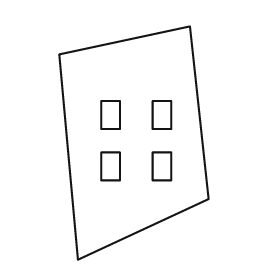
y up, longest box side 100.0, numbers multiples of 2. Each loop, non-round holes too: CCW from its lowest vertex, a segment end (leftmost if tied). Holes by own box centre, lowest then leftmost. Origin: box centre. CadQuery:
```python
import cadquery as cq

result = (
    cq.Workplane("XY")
    .moveTo(-24.0, -50.0)
    .lineTo(32.0, -24.0)
    .lineTo(24.0, 50.0)
    .lineTo(-32.0, 38.0)
    .close()
    .moveTo(-14.0, -16.0)
    .lineTo(-6.0, -16.0)
    .lineTo(-6.0, -4.0)
    .lineTo(-14.0, -4.0)
    .close()
    .moveTo(8.0, -16.0)
    .lineTo(16.0, -16.0)
    .lineTo(16.0, -4.0)
    .lineTo(8.0, -4.0)
    .close()
    .moveTo(-14.0, 6.0)
    .lineTo(-6.0, 6.0)
    .lineTo(-6.0, 18.0)
    .lineTo(-14.0, 18.0)
    .close()
    .moveTo(8.0, 6.0)
    .lineTo(16.0, 6.0)
    .lineTo(16.0, 18.0)
    .lineTo(8.0, 18.0)
    .close()
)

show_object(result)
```